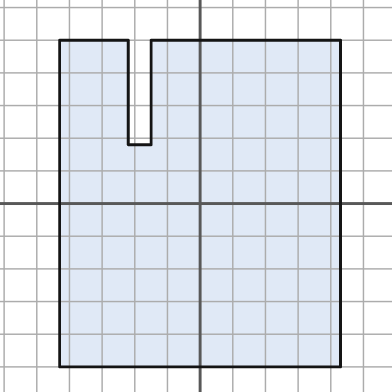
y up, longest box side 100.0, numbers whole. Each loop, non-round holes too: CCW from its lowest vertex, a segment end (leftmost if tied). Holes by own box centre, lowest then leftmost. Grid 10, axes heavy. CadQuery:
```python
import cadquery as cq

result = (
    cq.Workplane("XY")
    .moveTo(-43.0, -50.0)
    .lineTo(43.0, -50.0)
    .lineTo(43.0, 50.0)
    .lineTo(-15.0, 50.0)
    .lineTo(-15.0, 18.0)
    .lineTo(-22.0, 18.0)
    .lineTo(-22.0, 50.0)
    .lineTo(-43.0, 50.0)
    .close()
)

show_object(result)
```